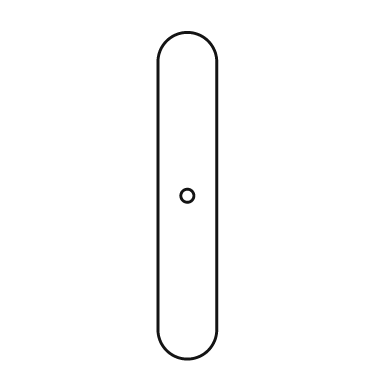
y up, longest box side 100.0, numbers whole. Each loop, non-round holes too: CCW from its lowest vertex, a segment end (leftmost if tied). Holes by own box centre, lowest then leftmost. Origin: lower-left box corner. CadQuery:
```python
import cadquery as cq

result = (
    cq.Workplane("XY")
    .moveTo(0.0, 9.0)
    .threePointArc((9.0, 0.0), (18.0, 9.0))
    .lineTo(18.0, 91.0)
    .threePointArc((9.0, 100.0), (0.0, 91.0))
    .close()
    .moveTo(9.0, 50.0)
    .circle(2.0)
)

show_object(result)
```